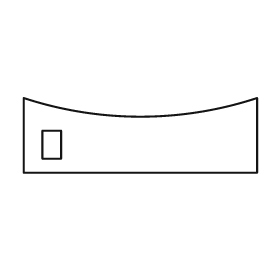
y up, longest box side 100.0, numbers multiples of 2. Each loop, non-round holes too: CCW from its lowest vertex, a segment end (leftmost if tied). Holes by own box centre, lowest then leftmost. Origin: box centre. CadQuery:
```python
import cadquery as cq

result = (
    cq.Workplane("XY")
    .moveTo(-50.0, -16.0)
    .lineTo(50.0, -16.0)
    .lineTo(50.0, 16.0)
    .threePointArc((0.0, 8.0), (-50.0, 16.0))
    .close()
    .moveTo(-42.0, -10.0)
    .lineTo(-34.0, -10.0)
    .lineTo(-34.0, 2.0)
    .lineTo(-42.0, 2.0)
    .close()
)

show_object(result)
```